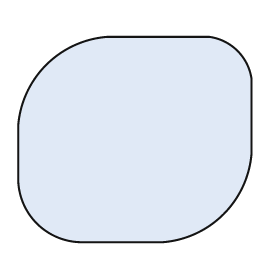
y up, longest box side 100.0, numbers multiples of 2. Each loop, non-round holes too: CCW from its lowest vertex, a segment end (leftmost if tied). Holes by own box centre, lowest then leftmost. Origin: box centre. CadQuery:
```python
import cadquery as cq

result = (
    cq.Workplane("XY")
    .moveTo(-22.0, -44.0)
    .lineTo(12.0, -44.0)
    .threePointArc((38.0, -32.0), (50.0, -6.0))
    .lineTo(50.0, 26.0)
    .threePointArc((44.0, 38.0), (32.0, 44.0))
    .lineTo(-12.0, 44.0)
    .threePointArc((-38.0, 32.0), (-50.0, 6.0))
    .lineTo(-50.0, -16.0)
    .threePointArc((-42.0, -36.0), (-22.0, -44.0))
    .close()
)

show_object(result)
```